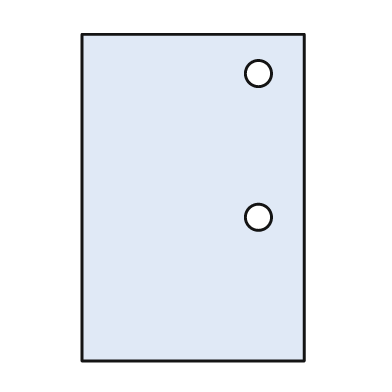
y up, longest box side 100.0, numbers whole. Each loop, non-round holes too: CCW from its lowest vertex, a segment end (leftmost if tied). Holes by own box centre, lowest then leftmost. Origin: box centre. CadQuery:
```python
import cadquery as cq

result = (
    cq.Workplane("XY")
    .moveTo(-34.0, -50.0)
    .lineTo(34.0, -50.0)
    .lineTo(34.0, 50.0)
    .lineTo(-34.0, 50.0)
    .close()
    .moveTo(20.0, -6.0)
    .circle(4.0)
    .moveTo(20.0, 38.0)
    .circle(4.0)
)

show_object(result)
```